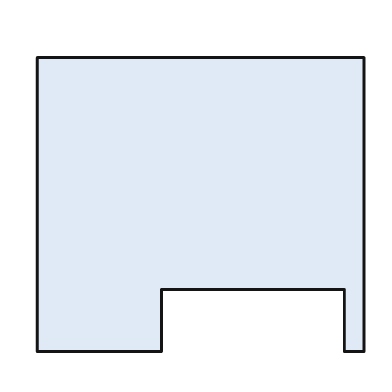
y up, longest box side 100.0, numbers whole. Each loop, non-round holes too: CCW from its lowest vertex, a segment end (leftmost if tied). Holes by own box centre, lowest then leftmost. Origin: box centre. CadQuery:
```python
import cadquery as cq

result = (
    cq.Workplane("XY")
    .moveTo(-50.0, -45.0)
    .lineTo(-12.0, -45.0)
    .lineTo(-12.0, -26.0)
    .lineTo(44.0, -26.0)
    .lineTo(44.0, -45.0)
    .lineTo(50.0, -45.0)
    .lineTo(50.0, 45.0)
    .lineTo(-50.0, 45.0)
    .close()
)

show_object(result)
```